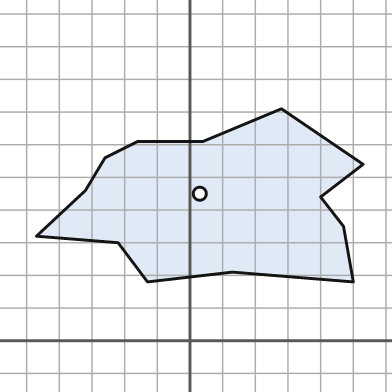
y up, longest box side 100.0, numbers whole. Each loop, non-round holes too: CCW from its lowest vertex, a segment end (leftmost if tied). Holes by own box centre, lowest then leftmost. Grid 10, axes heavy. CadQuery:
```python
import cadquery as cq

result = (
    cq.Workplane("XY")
    .moveTo(-13.0, 18.0)
    .lineTo(13.0, 21.0)
    .lineTo(50.0, 18.0)
    .lineTo(47.0, 35.0)
    .lineTo(40.0, 44.0)
    .lineTo(53.0, 54.0)
    .lineTo(28.0, 71.0)
    .lineTo(4.0, 61.0)
    .lineTo(-16.0, 61.0)
    .lineTo(-26.0, 56.0)
    .lineTo(-32.0, 46.0)
    .lineTo(-47.0, 32.0)
    .lineTo(-22.0, 30.0)
    .close()
    .moveTo(3.0, 45.0)
    .circle(2.0)
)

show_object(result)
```